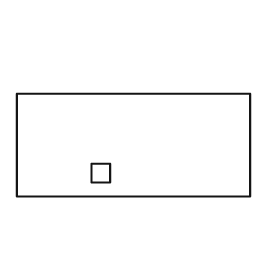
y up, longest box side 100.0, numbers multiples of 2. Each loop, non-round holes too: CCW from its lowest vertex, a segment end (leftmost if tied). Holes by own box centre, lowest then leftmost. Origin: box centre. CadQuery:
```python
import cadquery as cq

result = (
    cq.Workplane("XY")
    .moveTo(-50.0, -22.0)
    .lineTo(50.0, -22.0)
    .lineTo(50.0, 22.0)
    .lineTo(-50.0, 22.0)
    .close()
    .moveTo(-18.0, -16.0)
    .lineTo(-10.0, -16.0)
    .lineTo(-10.0, -8.0)
    .lineTo(-18.0, -8.0)
    .close()
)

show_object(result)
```